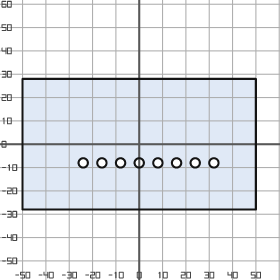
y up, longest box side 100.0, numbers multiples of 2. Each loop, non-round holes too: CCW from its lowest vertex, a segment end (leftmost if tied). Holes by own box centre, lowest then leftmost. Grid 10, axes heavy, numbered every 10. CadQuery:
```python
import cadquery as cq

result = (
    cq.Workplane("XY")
    .moveTo(-50.0, -28.0)
    .lineTo(50.0, -28.0)
    .lineTo(50.0, 28.0)
    .lineTo(-50.0, 28.0)
    .close()
    .moveTo(-24.0, -8.0)
    .circle(2.0)
    .moveTo(-16.0, -8.0)
    .circle(2.0)
    .moveTo(-8.0, -8.0)
    .circle(2.0)
    .moveTo(0.0, -8.0)
    .circle(2.0)
    .moveTo(8.0, -8.0)
    .circle(2.0)
    .moveTo(16.0, -8.0)
    .circle(2.0)
    .moveTo(24.0, -8.0)
    .circle(2.0)
    .moveTo(32.0, -8.0)
    .circle(2.0)
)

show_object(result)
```